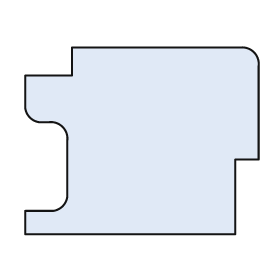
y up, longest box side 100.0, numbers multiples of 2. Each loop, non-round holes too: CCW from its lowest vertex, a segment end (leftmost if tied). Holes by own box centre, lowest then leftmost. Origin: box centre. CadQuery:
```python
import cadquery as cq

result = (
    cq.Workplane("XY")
    .moveTo(-50.0, -40.0)
    .lineTo(40.0, -40.0)
    .lineTo(40.0, -8.0)
    .lineTo(50.0, -8.0)
    .lineTo(50.0, 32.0)
    .threePointArc((48.0, 38.0), (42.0, 40.0))
    .lineTo(-30.0, 40.0)
    .lineTo(-30.0, 28.0)
    .lineTo(-50.0, 28.0)
    .lineTo(-50.0, 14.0)
    .threePointArc((-48.0, 10.0), (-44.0, 8.0))
    .lineTo(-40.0, 8.0)
    .threePointArc((-34.0, 6.0), (-32.0, 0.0))
    .lineTo(-32.0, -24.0)
    .threePointArc((-34.0, -28.0), (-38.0, -30.0))
    .lineTo(-50.0, -30.0)
    .close()
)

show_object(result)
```